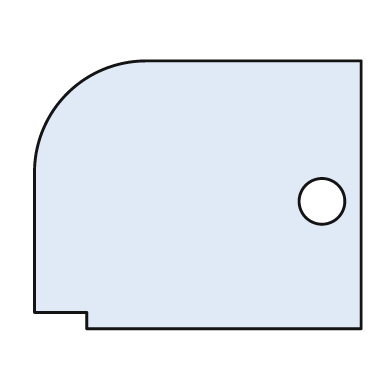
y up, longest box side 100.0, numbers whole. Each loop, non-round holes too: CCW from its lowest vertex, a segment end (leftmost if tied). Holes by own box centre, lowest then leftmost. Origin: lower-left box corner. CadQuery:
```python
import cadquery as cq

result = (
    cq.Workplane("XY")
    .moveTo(16.0, 0.0)
    .lineTo(100.0, 0.0)
    .lineTo(100.0, 82.0)
    .lineTo(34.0, 82.0)
    .threePointArc((10.0, 72.0), (0.0, 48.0))
    .lineTo(0.0, 5.0)
    .lineTo(16.0, 5.0)
    .close()
    .moveTo(88.0, 39.0)
    .circle(7.0)
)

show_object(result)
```